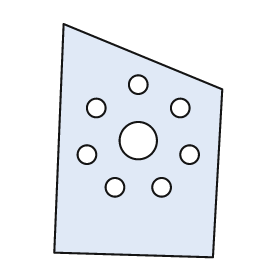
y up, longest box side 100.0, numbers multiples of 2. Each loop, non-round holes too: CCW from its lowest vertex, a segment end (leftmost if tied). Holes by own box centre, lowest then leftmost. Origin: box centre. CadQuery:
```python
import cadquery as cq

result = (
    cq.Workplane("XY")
    .moveTo(32.0, -50.0)
    .lineTo(36.0, 22.0)
    .lineTo(-32.0, 50.0)
    .lineTo(-36.0, -48.0)
    .close()
    .moveTo(-10.0, -20.0)
    .circle(4.0)
    .moveTo(10.0, -20.0)
    .circle(4.0)
    .moveTo(-22.0, -6.0)
    .circle(4.0)
    .moveTo(22.0, -6.0)
    .circle(4.0)
    .moveTo(0.0, 0.0)
    .circle(8.0)
    .moveTo(-18.0, 14.0)
    .circle(4.0)
    .moveTo(18.0, 14.0)
    .circle(4.0)
    .moveTo(0.0, 24.0)
    .circle(4.0)
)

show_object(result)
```